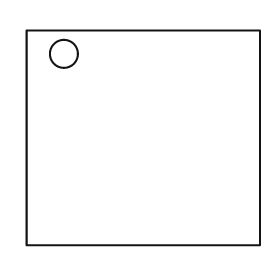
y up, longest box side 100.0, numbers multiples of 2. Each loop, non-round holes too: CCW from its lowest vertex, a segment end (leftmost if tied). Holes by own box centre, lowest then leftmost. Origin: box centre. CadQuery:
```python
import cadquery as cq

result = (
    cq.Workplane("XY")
    .moveTo(-50.0, -46.0)
    .lineTo(50.0, -46.0)
    .lineTo(50.0, 46.0)
    .lineTo(-50.0, 46.0)
    .close()
    .moveTo(-34.0, 36.0)
    .circle(6.0)
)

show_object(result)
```